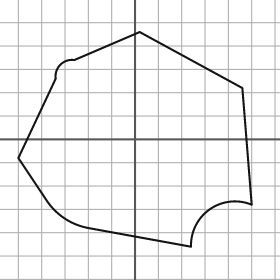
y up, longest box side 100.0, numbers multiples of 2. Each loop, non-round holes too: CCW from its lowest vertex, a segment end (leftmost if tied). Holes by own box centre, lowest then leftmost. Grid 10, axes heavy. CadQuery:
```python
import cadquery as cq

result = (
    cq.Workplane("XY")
    .moveTo(24.0, -46.0)
    .threePointArc((32.0, -30.0), (50.0, -28.0))
    .lineTo(46.0, 22.0)
    .lineTo(2.0, 46.0)
    .lineTo(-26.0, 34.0)
    .threePointArc((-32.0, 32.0), (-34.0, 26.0))
    .lineTo(-50.0, -8.0)
    .lineTo(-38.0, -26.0)
    .threePointArc((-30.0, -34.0), (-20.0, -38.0))
    .close()
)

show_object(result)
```